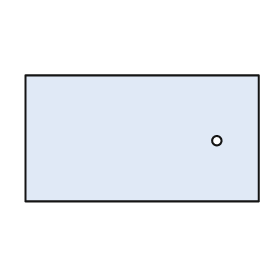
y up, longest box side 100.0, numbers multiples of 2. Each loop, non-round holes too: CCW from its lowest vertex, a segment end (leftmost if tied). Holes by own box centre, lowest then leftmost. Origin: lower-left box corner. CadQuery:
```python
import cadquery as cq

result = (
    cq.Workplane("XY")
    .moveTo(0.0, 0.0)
    .lineTo(100.0, 0.0)
    .lineTo(100.0, 54.0)
    .lineTo(0.0, 54.0)
    .close()
    .moveTo(82.0, 26.0)
    .circle(2.0)
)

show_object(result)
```